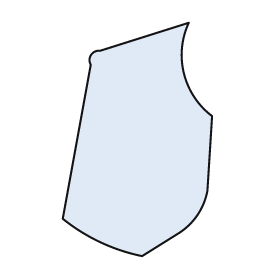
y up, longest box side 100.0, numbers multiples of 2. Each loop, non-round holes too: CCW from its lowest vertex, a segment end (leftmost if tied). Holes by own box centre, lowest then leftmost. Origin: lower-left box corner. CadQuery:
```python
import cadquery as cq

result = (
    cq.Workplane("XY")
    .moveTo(34.0, 0.0)
    .lineTo(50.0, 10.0)
    .threePointArc((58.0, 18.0), (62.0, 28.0))
    .lineTo(64.0, 60.0)
    .threePointArc((52.0, 78.0), (54.0, 100.0))
    .lineTo(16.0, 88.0)
    .threePointArc((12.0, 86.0), (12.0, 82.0))
    .lineTo(0.0, 16.0)
    .threePointArc((16.0, 6.0), (34.0, 0.0))
    .close()
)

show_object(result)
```